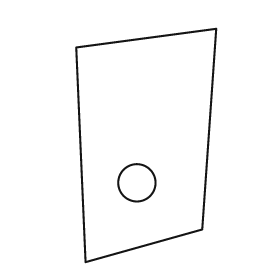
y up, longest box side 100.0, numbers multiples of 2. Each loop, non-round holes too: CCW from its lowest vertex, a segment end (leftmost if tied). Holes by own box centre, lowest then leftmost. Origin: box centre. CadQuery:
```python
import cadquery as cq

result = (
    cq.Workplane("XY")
    .moveTo(-26.0, -50.0)
    .lineTo(24.0, -36.0)
    .lineTo(30.0, 50.0)
    .lineTo(-30.0, 42.0)
    .close()
    .moveTo(-4.0, -16.0)
    .circle(8.0)
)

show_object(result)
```